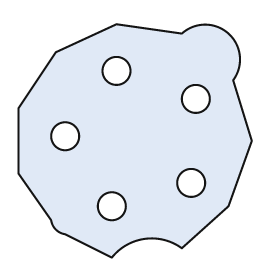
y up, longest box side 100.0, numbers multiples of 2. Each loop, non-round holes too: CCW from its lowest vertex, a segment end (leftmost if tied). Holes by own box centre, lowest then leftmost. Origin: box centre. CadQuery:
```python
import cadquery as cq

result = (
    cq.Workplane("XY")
    .moveTo(-10.0, -50.0)
    .threePointArc((4.0, -42.0), (20.0, -46.0))
    .lineTo(40.0, -28.0)
    .lineTo(50.0, 0.0)
    .lineTo(42.0, 26.0)
    .threePointArc((40.0, 46.0), (20.0, 46.0))
    .lineTo(-8.0, 50.0)
    .lineTo(-34.0, 38.0)
    .lineTo(-50.0, 14.0)
    .lineTo(-50.0, -14.0)
    .lineTo(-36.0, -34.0)
    .threePointArc((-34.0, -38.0), (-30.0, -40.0))
    .close()
    .moveTo(-10.0, -28.0)
    .circle(6.0)
    .moveTo(24.0, -18.0)
    .circle(6.0)
    .moveTo(-30.0, 2.0)
    .circle(6.0)
    .moveTo(26.0, 18.0)
    .circle(6.0)
    .moveTo(-8.0, 30.0)
    .circle(6.0)
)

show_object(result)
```